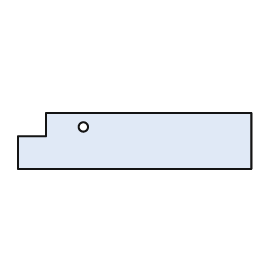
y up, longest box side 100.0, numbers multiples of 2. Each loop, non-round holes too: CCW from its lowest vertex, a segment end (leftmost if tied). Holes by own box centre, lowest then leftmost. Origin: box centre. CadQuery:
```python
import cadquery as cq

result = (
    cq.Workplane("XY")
    .moveTo(-50.0, -12.0)
    .lineTo(50.0, -12.0)
    .lineTo(50.0, 12.0)
    .lineTo(-38.0, 12.0)
    .lineTo(-38.0, 2.0)
    .lineTo(-50.0, 2.0)
    .close()
    .moveTo(-22.0, 6.0)
    .circle(2.0)
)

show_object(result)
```